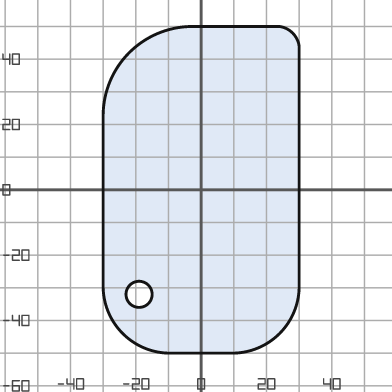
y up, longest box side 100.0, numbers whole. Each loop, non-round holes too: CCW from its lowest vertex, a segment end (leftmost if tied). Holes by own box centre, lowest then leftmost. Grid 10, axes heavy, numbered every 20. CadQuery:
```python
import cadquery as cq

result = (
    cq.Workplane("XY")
    .moveTo(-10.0, -50.0)
    .lineTo(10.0, -50.0)
    .threePointArc((24.0, -44.0), (30.0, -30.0))
    .lineTo(30.0, 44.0)
    .threePointArc((28.0, 48.0), (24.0, 50.0))
    .lineTo(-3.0, 50.0)
    .threePointArc((-22.0, 42.0), (-30.0, 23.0))
    .lineTo(-30.0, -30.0)
    .threePointArc((-24.0, -44.0), (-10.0, -50.0))
    .close()
    .moveTo(-19.0, -32.0)
    .circle(4.0)
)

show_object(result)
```